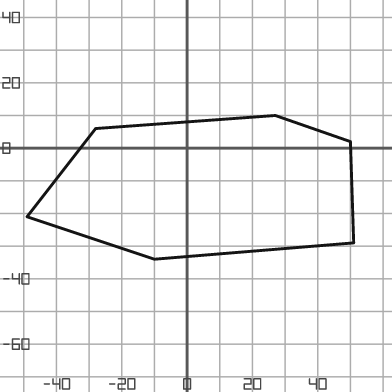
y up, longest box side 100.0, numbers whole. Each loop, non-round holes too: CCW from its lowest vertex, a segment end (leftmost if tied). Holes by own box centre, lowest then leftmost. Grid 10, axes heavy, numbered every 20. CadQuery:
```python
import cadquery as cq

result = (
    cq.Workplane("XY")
    .moveTo(-10.0, -34.0)
    .lineTo(51.0, -29.0)
    .lineTo(50.0, 2.0)
    .lineTo(27.0, 10.0)
    .lineTo(-28.0, 6.0)
    .lineTo(-49.0, -21.0)
    .close()
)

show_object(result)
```